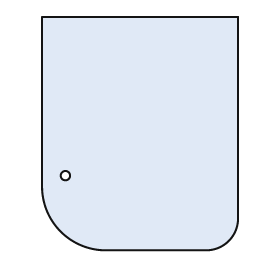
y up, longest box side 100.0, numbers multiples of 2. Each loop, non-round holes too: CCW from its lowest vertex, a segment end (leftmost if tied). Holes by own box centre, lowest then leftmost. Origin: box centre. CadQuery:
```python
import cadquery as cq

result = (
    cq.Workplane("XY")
    .moveTo(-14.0, -50.0)
    .lineTo(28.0, -50.0)
    .threePointArc((38.0, -46.0), (42.0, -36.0))
    .lineTo(42.0, 50.0)
    .lineTo(-42.0, 50.0)
    .lineTo(-42.0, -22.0)
    .threePointArc((-34.0, -42.0), (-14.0, -50.0))
    .close()
    .moveTo(-32.0, -18.0)
    .circle(2.0)
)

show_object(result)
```